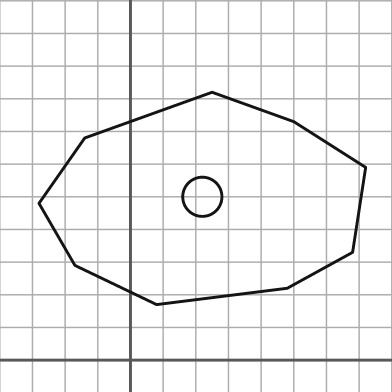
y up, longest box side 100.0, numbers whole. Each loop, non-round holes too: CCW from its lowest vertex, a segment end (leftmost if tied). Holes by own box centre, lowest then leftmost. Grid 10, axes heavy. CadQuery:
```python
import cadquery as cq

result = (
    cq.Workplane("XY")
    .moveTo(8.0, 17.0)
    .lineTo(48.0, 22.0)
    .lineTo(68.0, 33.0)
    .lineTo(72.0, 59.0)
    .lineTo(50.0, 73.0)
    .lineTo(25.0, 82.0)
    .lineTo(-14.0, 68.0)
    .lineTo(-28.0, 48.0)
    .lineTo(-17.0, 29.0)
    .close()
    .moveTo(22.0, 50.0)
    .circle(6.0)
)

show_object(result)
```